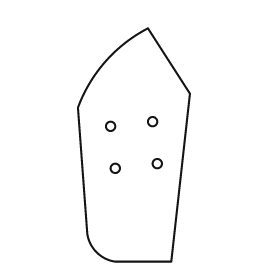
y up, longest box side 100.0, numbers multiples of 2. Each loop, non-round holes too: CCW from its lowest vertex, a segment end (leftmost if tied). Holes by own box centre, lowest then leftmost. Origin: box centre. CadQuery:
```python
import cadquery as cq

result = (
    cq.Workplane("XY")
    .moveTo(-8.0, -50.0)
    .lineTo(16.0, -50.0)
    .lineTo(24.0, 22.0)
    .lineTo(6.0, 50.0)
    .threePointArc((-12.0, 36.0), (-24.0, 16.0))
    .lineTo(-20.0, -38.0)
    .threePointArc((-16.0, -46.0), (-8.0, -50.0))
    .close()
    .moveTo(-8.0, -10.0)
    .circle(2.0)
    .moveTo(10.0, -8.0)
    .circle(2.0)
    .moveTo(-10.0, 8.0)
    .circle(2.0)
    .moveTo(8.0, 10.0)
    .circle(2.0)
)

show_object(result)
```